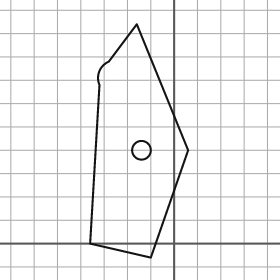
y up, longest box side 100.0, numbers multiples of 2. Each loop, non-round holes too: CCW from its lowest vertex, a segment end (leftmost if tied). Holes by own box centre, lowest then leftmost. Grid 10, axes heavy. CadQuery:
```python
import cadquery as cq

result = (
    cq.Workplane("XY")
    .moveTo(-10.0, -6.0)
    .lineTo(6.0, 40.0)
    .lineTo(-16.0, 94.0)
    .lineTo(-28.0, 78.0)
    .threePointArc((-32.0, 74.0), (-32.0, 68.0))
    .lineTo(-36.0, 0.0)
    .close()
    .moveTo(-14.0, 40.0)
    .circle(4.0)
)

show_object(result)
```